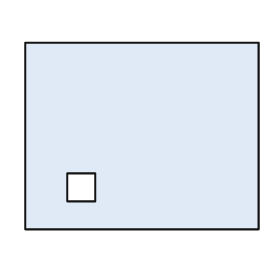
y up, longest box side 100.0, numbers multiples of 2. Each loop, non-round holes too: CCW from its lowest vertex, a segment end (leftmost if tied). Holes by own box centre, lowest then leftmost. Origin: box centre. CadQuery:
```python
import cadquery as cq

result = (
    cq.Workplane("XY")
    .moveTo(-50.0, -40.0)
    .lineTo(50.0, -40.0)
    .lineTo(50.0, 40.0)
    .lineTo(-50.0, 40.0)
    .close()
    .moveTo(-32.0, -28.0)
    .lineTo(-20.0, -28.0)
    .lineTo(-20.0, -16.0)
    .lineTo(-32.0, -16.0)
    .close()
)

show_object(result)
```